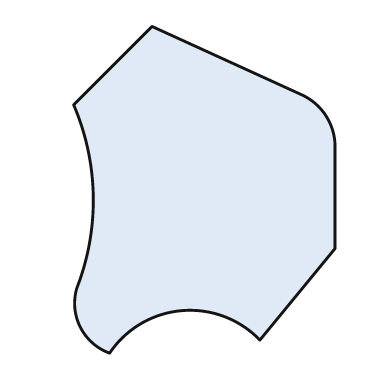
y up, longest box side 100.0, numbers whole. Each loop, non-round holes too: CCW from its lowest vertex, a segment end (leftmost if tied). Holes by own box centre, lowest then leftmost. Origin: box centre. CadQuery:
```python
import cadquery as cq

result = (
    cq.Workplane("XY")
    .moveTo(-29.0, -50.0)
    .threePointArc((-7.0, -37.0), (17.0, -46.0))
    .lineTo(40.0, -18.0)
    .lineTo(40.0, 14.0)
    .threePointArc((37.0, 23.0), (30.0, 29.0))
    .lineTo(-16.0, 50.0)
    .lineTo(-40.0, 26.0)
    .threePointArc((-34.0, -2.0), (-39.0, -30.0))
    .threePointArc((-38.0, -42.0), (-29.0, -50.0))
    .close()
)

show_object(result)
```